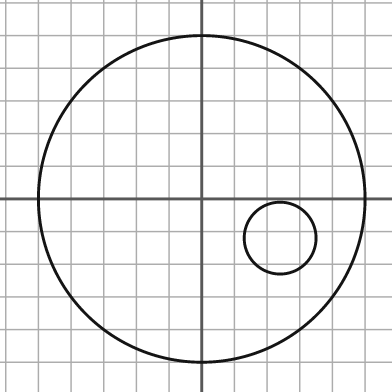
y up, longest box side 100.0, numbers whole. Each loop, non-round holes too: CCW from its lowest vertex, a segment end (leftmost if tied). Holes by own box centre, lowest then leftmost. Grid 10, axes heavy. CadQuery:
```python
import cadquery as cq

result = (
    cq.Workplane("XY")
    .moveTo(0.0, 0.0)
    .circle(50.0)
    .moveTo(24.0, -12.0)
    .circle(11.0)
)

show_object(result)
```